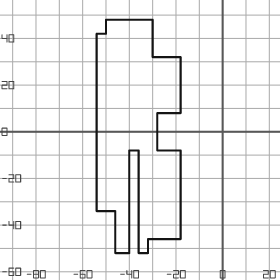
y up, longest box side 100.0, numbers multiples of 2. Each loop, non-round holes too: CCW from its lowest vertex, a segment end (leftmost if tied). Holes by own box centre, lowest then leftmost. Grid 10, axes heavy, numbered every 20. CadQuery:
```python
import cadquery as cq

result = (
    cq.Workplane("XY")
    .moveTo(-46.0, -52.0)
    .lineTo(-40.0, -52.0)
    .lineTo(-40.0, -8.0)
    .lineTo(-36.0, -8.0)
    .lineTo(-36.0, -52.0)
    .lineTo(-32.0, -52.0)
    .lineTo(-32.0, -46.0)
    .lineTo(-18.0, -46.0)
    .lineTo(-18.0, -8.0)
    .lineTo(-28.0, -8.0)
    .lineTo(-28.0, 8.0)
    .lineTo(-18.0, 8.0)
    .lineTo(-18.0, 32.0)
    .lineTo(-30.0, 32.0)
    .lineTo(-30.0, 48.0)
    .lineTo(-50.0, 48.0)
    .lineTo(-50.0, 42.0)
    .lineTo(-54.0, 42.0)
    .lineTo(-54.0, -34.0)
    .lineTo(-46.0, -34.0)
    .close()
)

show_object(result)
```